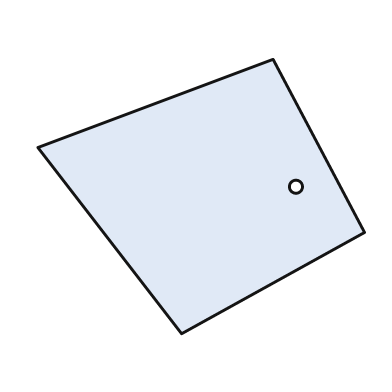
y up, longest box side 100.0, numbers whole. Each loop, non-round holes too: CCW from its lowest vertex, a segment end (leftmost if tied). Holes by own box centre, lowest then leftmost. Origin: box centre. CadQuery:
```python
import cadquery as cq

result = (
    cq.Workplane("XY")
    .moveTo(-6.0, -42.0)
    .lineTo(50.0, -11.0)
    .lineTo(22.0, 42.0)
    .lineTo(-50.0, 15.0)
    .close()
    .moveTo(29.0, 3.0)
    .circle(2.0)
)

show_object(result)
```